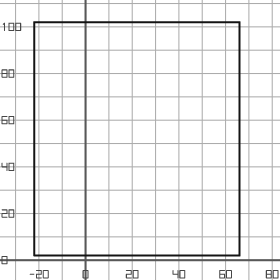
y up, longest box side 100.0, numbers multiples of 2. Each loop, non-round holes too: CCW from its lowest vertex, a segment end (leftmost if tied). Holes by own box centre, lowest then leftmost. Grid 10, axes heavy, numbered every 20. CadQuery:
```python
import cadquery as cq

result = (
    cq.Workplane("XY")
    .moveTo(-22.0, 2.0)
    .lineTo(66.0, 2.0)
    .lineTo(66.0, 102.0)
    .lineTo(-22.0, 102.0)
    .close()
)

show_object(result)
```